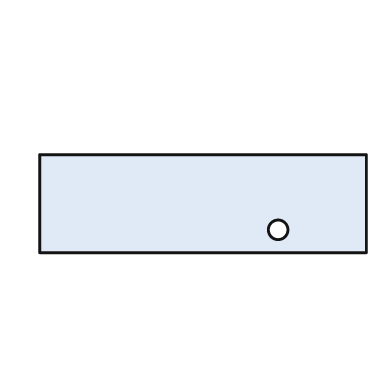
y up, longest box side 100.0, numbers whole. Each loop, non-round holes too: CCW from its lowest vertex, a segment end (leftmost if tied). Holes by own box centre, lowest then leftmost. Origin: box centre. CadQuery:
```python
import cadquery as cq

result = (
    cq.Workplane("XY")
    .moveTo(-50.0, -15.0)
    .lineTo(50.0, -15.0)
    .lineTo(50.0, 15.0)
    .lineTo(-50.0, 15.0)
    .close()
    .moveTo(23.0, -8.0)
    .circle(3.0)
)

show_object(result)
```